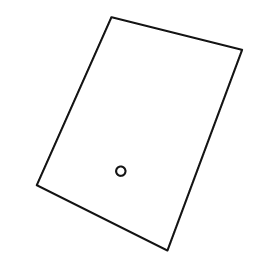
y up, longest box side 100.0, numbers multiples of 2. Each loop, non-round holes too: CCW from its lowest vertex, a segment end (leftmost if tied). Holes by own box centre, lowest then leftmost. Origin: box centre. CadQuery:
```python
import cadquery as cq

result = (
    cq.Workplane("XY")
    .moveTo(12.0, -50.0)
    .lineTo(44.0, 36.0)
    .lineTo(-12.0, 50.0)
    .lineTo(-44.0, -22.0)
    .close()
    .moveTo(-8.0, -16.0)
    .circle(2.0)
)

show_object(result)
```